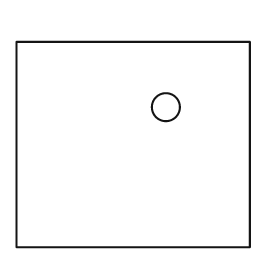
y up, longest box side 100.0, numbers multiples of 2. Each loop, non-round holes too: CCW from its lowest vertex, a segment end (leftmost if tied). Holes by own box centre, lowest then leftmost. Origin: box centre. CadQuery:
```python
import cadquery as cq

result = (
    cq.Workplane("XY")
    .moveTo(-50.0, -44.0)
    .lineTo(50.0, -44.0)
    .lineTo(50.0, 44.0)
    .lineTo(-50.0, 44.0)
    .close()
    .moveTo(14.0, 16.0)
    .circle(6.0)
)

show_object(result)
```